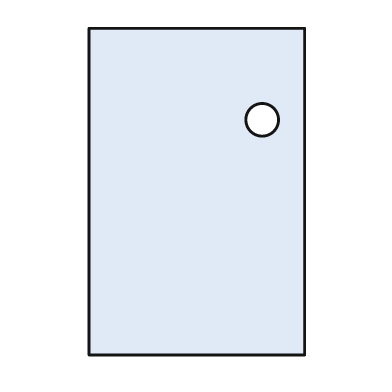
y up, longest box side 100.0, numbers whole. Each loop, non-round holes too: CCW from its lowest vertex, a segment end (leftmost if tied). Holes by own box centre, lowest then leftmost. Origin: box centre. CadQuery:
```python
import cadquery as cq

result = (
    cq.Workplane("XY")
    .moveTo(-33.0, -50.0)
    .lineTo(33.0, -50.0)
    .lineTo(33.0, 50.0)
    .lineTo(-33.0, 50.0)
    .close()
    .moveTo(20.0, 22.0)
    .circle(5.0)
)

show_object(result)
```